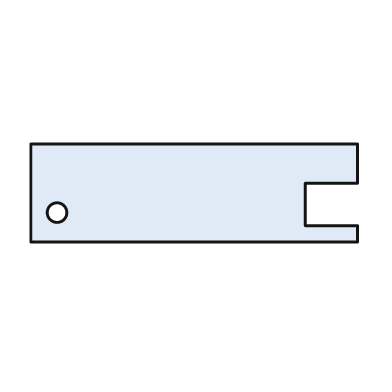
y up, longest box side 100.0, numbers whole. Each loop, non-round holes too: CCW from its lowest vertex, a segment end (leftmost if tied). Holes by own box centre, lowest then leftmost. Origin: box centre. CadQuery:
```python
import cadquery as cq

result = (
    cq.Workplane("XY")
    .moveTo(-50.0, -15.0)
    .lineTo(50.0, -15.0)
    .lineTo(50.0, -10.0)
    .lineTo(34.0, -10.0)
    .lineTo(34.0, 3.0)
    .lineTo(50.0, 3.0)
    .lineTo(50.0, 15.0)
    .lineTo(-50.0, 15.0)
    .close()
    .moveTo(-42.0, -6.0)
    .circle(3.0)
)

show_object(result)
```